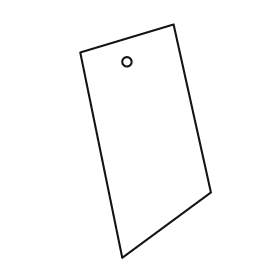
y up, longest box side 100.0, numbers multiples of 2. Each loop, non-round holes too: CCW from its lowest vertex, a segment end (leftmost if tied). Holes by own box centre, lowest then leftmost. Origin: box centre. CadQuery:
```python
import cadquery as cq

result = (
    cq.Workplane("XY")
    .moveTo(-10.0, -50.0)
    .lineTo(28.0, -22.0)
    .lineTo(12.0, 50.0)
    .lineTo(-28.0, 38.0)
    .close()
    .moveTo(-8.0, 34.0)
    .circle(2.0)
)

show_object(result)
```